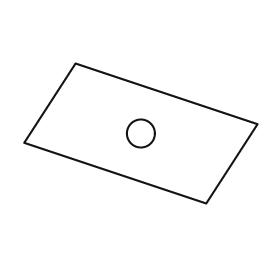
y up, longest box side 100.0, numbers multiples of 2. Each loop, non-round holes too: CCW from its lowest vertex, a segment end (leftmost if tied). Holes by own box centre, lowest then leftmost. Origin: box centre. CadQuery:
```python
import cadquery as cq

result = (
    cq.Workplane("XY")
    .moveTo(28.0, -30.0)
    .lineTo(50.0, 4.0)
    .lineTo(-28.0, 30.0)
    .lineTo(-50.0, -4.0)
    .close()
    .moveTo(0.0, 0.0)
    .circle(6.0)
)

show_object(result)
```